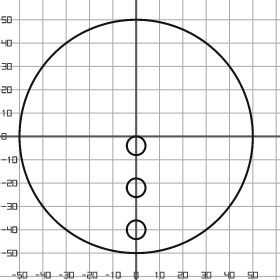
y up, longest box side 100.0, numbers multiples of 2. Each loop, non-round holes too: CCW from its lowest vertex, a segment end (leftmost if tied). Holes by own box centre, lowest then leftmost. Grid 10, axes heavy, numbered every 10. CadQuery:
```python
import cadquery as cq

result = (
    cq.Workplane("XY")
    .moveTo(0.0, 0.0)
    .circle(50.0)
    .moveTo(0.0, -40.0)
    .circle(4.0)
    .moveTo(0.0, -22.0)
    .circle(4.0)
    .moveTo(0.0, -4.0)
    .circle(4.0)
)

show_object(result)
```